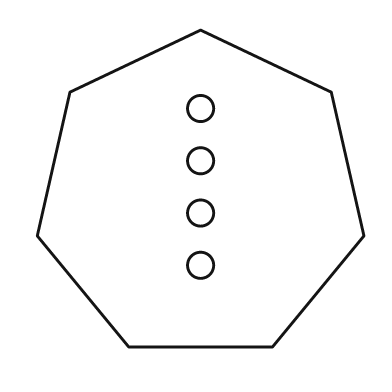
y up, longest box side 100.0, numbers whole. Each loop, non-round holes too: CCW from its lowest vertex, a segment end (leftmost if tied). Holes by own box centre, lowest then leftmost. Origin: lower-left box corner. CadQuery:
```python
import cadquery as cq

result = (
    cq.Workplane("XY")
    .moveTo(28.0, 0.0)
    .lineTo(72.0, 0.0)
    .lineTo(100.0, 34.0)
    .lineTo(90.0, 78.0)
    .lineTo(50.0, 97.0)
    .lineTo(10.0, 78.0)
    .lineTo(0.0, 34.0)
    .close()
    .moveTo(50.0, 25.0)
    .circle(4.0)
    .moveTo(50.0, 41.0)
    .circle(4.0)
    .moveTo(50.0, 57.0)
    .circle(4.0)
    .moveTo(50.0, 73.0)
    .circle(4.0)
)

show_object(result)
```